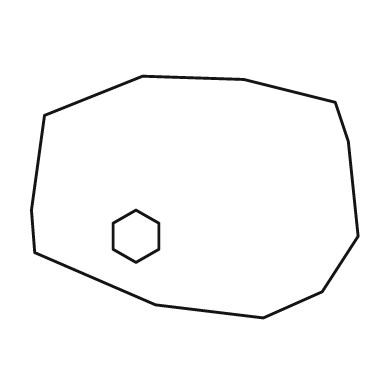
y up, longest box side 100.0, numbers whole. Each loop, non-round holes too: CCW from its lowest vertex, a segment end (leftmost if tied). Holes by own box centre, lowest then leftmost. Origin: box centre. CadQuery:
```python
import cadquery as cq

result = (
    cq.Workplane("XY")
    .moveTo(21.0, -37.0)
    .lineTo(39.0, -29.0)
    .lineTo(50.0, -12.0)
    .lineTo(47.0, 17.0)
    .lineTo(43.0, 29.0)
    .lineTo(15.0, 36.0)
    .lineTo(-16.0, 37.0)
    .lineTo(-46.0, 25.0)
    .lineTo(-50.0, -4.0)
    .lineTo(-49.0, -17.0)
    .lineTo(-12.0, -33.0)
    .close()
    .moveTo(-18.0, -20.0)
    .lineTo(-11.0, -16.0)
    .lineTo(-11.0, -8.0)
    .lineTo(-18.0, -4.0)
    .lineTo(-25.0, -8.0)
    .lineTo(-25.0, -16.0)
    .close()
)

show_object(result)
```